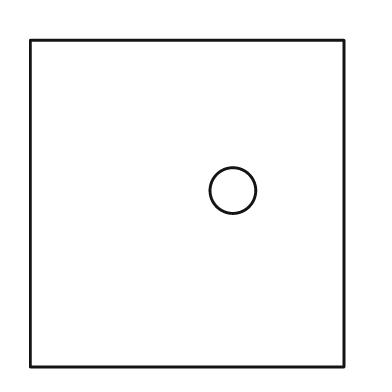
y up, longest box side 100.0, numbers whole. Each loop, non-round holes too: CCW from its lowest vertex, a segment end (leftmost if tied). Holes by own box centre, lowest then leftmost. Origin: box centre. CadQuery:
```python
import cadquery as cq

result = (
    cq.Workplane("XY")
    .moveTo(-48.0, -50.0)
    .lineTo(48.0, -50.0)
    .lineTo(48.0, 50.0)
    .lineTo(-48.0, 50.0)
    .close()
    .moveTo(14.0, 4.0)
    .circle(7.0)
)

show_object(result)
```